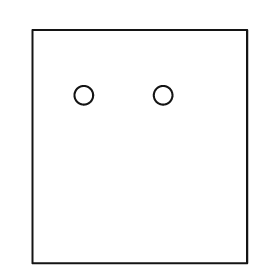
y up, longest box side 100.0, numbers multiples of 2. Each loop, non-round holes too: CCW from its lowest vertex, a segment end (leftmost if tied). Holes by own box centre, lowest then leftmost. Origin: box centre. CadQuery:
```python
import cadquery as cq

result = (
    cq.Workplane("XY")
    .moveTo(-46.0, -50.0)
    .lineTo(46.0, -50.0)
    .lineTo(46.0, 50.0)
    .lineTo(-46.0, 50.0)
    .close()
    .moveTo(-24.0, 22.0)
    .circle(4.0)
    .moveTo(10.0, 22.0)
    .circle(4.0)
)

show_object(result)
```